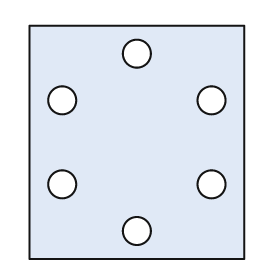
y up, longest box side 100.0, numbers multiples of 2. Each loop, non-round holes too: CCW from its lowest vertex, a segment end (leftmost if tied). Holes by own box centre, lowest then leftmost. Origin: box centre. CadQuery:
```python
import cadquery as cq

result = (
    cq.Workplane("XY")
    .moveTo(-46.0, -50.0)
    .lineTo(46.0, -50.0)
    .lineTo(46.0, 50.0)
    .lineTo(-46.0, 50.0)
    .close()
    .moveTo(0.0, -38.0)
    .circle(6.0)
    .moveTo(-32.0, -18.0)
    .circle(6.0)
    .moveTo(32.0, -18.0)
    .circle(6.0)
    .moveTo(-32.0, 18.0)
    .circle(6.0)
    .moveTo(32.0, 18.0)
    .circle(6.0)
    .moveTo(0.0, 38.0)
    .circle(6.0)
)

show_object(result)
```